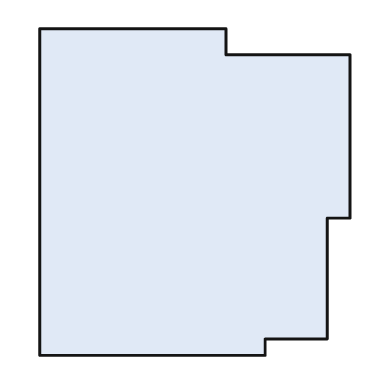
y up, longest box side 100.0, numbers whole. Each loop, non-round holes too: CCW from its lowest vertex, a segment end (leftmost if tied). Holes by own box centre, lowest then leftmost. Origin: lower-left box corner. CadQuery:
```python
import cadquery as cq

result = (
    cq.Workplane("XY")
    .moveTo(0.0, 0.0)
    .lineTo(69.0, 0.0)
    .lineTo(69.0, 5.0)
    .lineTo(88.0, 5.0)
    .lineTo(88.0, 42.0)
    .lineTo(95.0, 42.0)
    .lineTo(95.0, 92.0)
    .lineTo(57.0, 92.0)
    .lineTo(57.0, 100.0)
    .lineTo(0.0, 100.0)
    .close()
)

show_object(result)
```